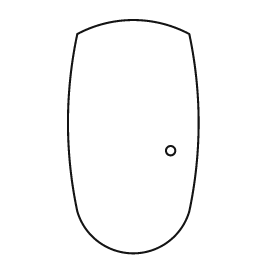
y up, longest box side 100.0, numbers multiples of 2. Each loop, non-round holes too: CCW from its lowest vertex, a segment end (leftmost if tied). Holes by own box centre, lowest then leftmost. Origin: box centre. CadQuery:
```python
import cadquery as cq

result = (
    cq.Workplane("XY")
    .moveTo(-24.0, -32.0)
    .threePointArc((0.0, -50.0), (24.0, -32.0))
    .threePointArc((28.0, 6.0), (24.0, 44.0))
    .threePointArc((0.0, 50.0), (-24.0, 44.0))
    .threePointArc((-28.0, 6.0), (-24.0, -32.0))
    .close()
    .moveTo(16.0, -6.0)
    .circle(2.0)
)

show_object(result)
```